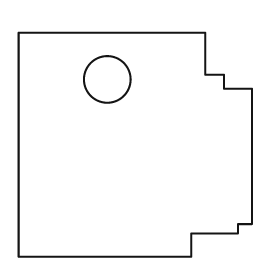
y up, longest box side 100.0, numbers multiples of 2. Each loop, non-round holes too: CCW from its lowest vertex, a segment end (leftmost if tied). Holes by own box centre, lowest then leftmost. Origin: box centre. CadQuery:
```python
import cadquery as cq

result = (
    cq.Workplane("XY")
    .moveTo(-50.0, -48.0)
    .lineTo(24.0, -48.0)
    .lineTo(24.0, -38.0)
    .lineTo(44.0, -38.0)
    .lineTo(44.0, -34.0)
    .lineTo(50.0, -34.0)
    .lineTo(50.0, 24.0)
    .lineTo(38.0, 24.0)
    .lineTo(38.0, 30.0)
    .lineTo(30.0, 30.0)
    .lineTo(30.0, 48.0)
    .lineTo(-50.0, 48.0)
    .close()
    .moveTo(-12.0, 28.0)
    .circle(10.0)
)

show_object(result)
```